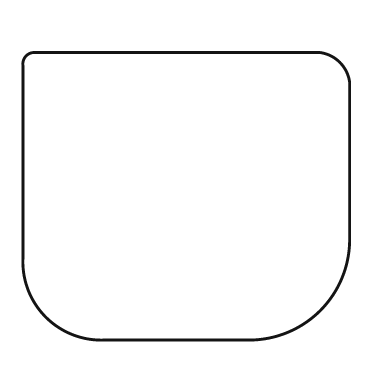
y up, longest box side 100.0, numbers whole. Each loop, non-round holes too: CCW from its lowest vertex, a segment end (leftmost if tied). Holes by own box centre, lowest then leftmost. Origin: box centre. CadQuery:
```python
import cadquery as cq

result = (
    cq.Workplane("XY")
    .moveTo(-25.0, -44.0)
    .lineTo(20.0, -44.0)
    .threePointArc((41.0, -35.0), (50.0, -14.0))
    .lineTo(50.0, 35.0)
    .threePointArc((47.0, 41.0), (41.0, 44.0))
    .lineTo(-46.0, 44.0)
    .threePointArc((-49.0, 43.0), (-50.0, 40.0))
    .lineTo(-50.0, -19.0)
    .threePointArc((-43.0, -37.0), (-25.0, -44.0))
    .close()
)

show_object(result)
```